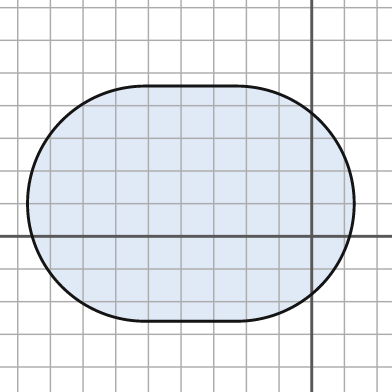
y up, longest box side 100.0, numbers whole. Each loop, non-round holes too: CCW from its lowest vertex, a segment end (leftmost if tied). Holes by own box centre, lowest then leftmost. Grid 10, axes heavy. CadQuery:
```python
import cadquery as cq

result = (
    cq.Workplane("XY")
    .moveTo(-51.0, -26.0)
    .lineTo(-23.0, -26.0)
    .threePointArc((13.0, 10.0), (-23.0, 46.0))
    .lineTo(-51.0, 46.0)
    .threePointArc((-87.0, 10.0), (-51.0, -26.0))
    .close()
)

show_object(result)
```